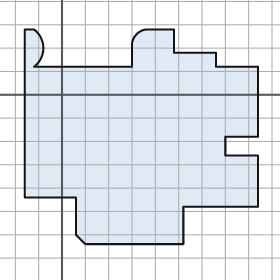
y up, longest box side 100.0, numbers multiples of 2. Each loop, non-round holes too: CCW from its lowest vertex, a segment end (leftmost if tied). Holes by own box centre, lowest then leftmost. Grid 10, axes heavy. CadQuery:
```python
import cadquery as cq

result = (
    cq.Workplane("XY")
    .moveTo(10.0, -64.0)
    .lineTo(52.0, -64.0)
    .lineTo(52.0, -48.0)
    .lineTo(84.0, -48.0)
    .lineTo(84.0, -26.0)
    .lineTo(70.0, -26.0)
    .lineTo(70.0, -18.0)
    .lineTo(84.0, -18.0)
    .lineTo(84.0, 12.0)
    .lineTo(66.0, 12.0)
    .lineTo(66.0, 18.0)
    .lineTo(48.0, 18.0)
    .lineTo(48.0, 28.0)
    .lineTo(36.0, 28.0)
    .threePointArc((32.0, 26.0), (30.0, 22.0))
    .lineTo(30.0, 12.0)
    .lineTo(-12.0, 12.0)
    .threePointArc((-8.0, 20.0), (-12.0, 28.0))
    .lineTo(-16.0, 28.0)
    .lineTo(-16.0, -44.0)
    .lineTo(6.0, -44.0)
    .lineTo(6.0, -60.0)
    .close()
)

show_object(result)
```